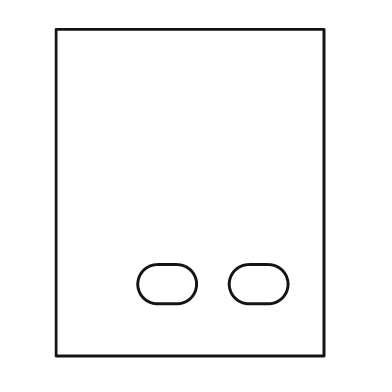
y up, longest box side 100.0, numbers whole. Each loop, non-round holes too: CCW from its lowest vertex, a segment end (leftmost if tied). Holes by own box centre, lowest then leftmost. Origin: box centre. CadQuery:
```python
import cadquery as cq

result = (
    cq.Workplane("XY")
    .moveTo(-41.0, -50.0)
    .lineTo(41.0, -50.0)
    .lineTo(41.0, 50.0)
    .lineTo(-41.0, 50.0)
    .close()
    .moveTo(-10.0, -34.0)
    .lineTo(-4.0, -34.0)
    .threePointArc((2.0, -28.0), (-4.0, -22.0))
    .lineTo(-10.0, -22.0)
    .threePointArc((-16.0, -28.0), (-10.0, -34.0))
    .close()
    .moveTo(18.0, -34.0)
    .lineTo(24.0, -34.0)
    .threePointArc((30.0, -28.0), (24.0, -22.0))
    .lineTo(18.0, -22.0)
    .threePointArc((12.0, -28.0), (18.0, -34.0))
    .close()
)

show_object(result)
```